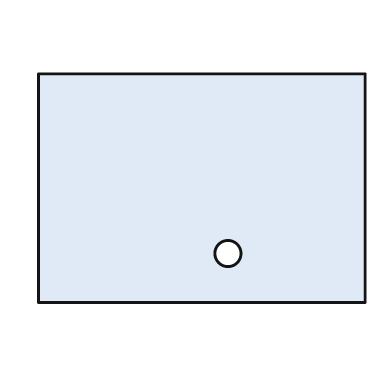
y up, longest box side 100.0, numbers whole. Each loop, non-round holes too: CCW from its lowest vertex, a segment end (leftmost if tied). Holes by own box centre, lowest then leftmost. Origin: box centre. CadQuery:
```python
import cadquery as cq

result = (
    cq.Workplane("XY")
    .moveTo(-50.0, -35.0)
    .lineTo(50.0, -35.0)
    .lineTo(50.0, 35.0)
    .lineTo(-50.0, 35.0)
    .close()
    .moveTo(8.0, -20.0)
    .circle(4.0)
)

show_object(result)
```